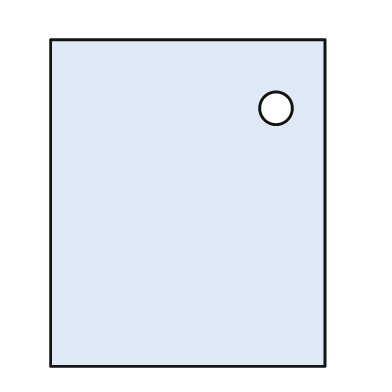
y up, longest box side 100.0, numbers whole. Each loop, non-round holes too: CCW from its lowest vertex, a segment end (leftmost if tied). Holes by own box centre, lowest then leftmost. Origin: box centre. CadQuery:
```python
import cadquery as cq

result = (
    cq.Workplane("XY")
    .moveTo(-42.0, -50.0)
    .lineTo(42.0, -50.0)
    .lineTo(42.0, 50.0)
    .lineTo(-42.0, 50.0)
    .close()
    .moveTo(27.0, 29.0)
    .circle(5.0)
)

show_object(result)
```